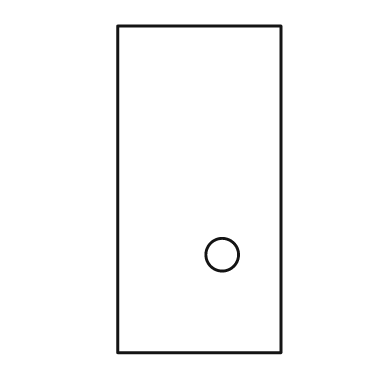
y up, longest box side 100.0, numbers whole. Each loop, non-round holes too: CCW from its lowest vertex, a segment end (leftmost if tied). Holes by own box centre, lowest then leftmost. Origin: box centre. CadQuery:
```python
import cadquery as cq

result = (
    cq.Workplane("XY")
    .moveTo(-25.0, -50.0)
    .lineTo(25.0, -50.0)
    .lineTo(25.0, 50.0)
    .lineTo(-25.0, 50.0)
    .close()
    .moveTo(7.0, -20.0)
    .circle(5.0)
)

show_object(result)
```